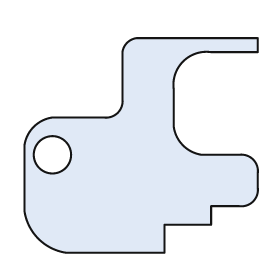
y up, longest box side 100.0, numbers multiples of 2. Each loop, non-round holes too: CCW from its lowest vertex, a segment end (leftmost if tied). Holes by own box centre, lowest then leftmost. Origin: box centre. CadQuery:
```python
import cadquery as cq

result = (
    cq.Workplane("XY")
    .moveTo(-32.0, -46.0)
    .lineTo(10.0, -46.0)
    .lineTo(10.0, -34.0)
    .lineTo(30.0, -34.0)
    .lineTo(30.0, -26.0)
    .lineTo(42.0, -26.0)
    .threePointArc((48.0, -24.0), (50.0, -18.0))
    .lineTo(50.0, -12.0)
    .threePointArc((48.0, -6.0), (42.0, -4.0))
    .lineTo(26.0, -4.0)
    .threePointArc((18.0, 0.0), (14.0, 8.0))
    .lineTo(14.0, 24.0)
    .threePointArc((18.0, 36.0), (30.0, 40.0))
    .lineTo(50.0, 40.0)
    .lineTo(50.0, 46.0)
    .lineTo(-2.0, 46.0)
    .threePointArc((-6.0, 44.0), (-8.0, 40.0))
    .lineTo(-8.0, 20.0)
    .threePointArc((-10.0, 14.0), (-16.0, 12.0))
    .lineTo(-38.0, 12.0)
    .threePointArc((-46.0, 8.0), (-50.0, 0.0))
    .lineTo(-50.0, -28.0)
    .threePointArc((-44.0, -40.0), (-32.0, -46.0))
    .close()
    .moveTo(-38.0, -4.0)
    .circle(8.0)
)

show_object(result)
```